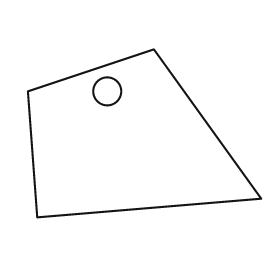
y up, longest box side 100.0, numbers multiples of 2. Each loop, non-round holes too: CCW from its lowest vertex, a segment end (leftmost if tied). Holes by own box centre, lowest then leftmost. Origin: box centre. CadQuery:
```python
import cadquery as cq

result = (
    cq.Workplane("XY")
    .moveTo(-46.0, -36.0)
    .lineTo(50.0, -28.0)
    .lineTo(4.0, 36.0)
    .lineTo(-50.0, 18.0)
    .close()
    .moveTo(-16.0, 18.0)
    .circle(6.0)
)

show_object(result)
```